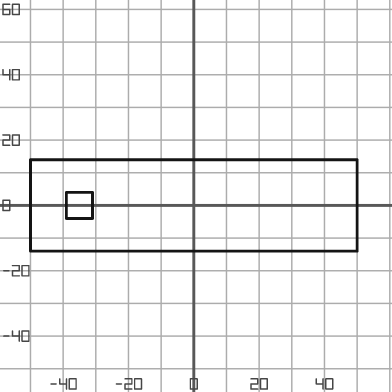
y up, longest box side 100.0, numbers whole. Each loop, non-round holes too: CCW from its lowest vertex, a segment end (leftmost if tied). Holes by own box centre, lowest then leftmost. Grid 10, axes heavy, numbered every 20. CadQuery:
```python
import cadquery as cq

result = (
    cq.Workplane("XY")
    .moveTo(-50.0, -14.0)
    .lineTo(50.0, -14.0)
    .lineTo(50.0, 14.0)
    .lineTo(-50.0, 14.0)
    .close()
    .moveTo(-39.0, -4.0)
    .lineTo(-31.0, -4.0)
    .lineTo(-31.0, 4.0)
    .lineTo(-39.0, 4.0)
    .close()
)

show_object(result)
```